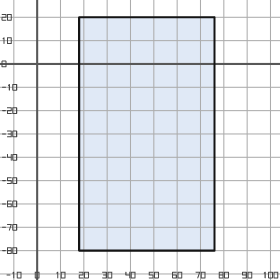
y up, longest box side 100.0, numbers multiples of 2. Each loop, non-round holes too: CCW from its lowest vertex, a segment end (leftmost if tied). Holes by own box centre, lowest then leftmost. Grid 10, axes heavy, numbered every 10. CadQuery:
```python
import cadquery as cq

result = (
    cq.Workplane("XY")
    .moveTo(18.0, -80.0)
    .lineTo(76.0, -80.0)
    .lineTo(76.0, 20.0)
    .lineTo(18.0, 20.0)
    .close()
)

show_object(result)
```